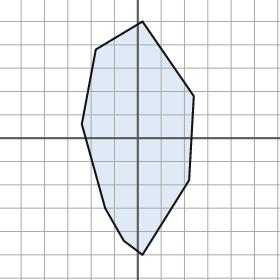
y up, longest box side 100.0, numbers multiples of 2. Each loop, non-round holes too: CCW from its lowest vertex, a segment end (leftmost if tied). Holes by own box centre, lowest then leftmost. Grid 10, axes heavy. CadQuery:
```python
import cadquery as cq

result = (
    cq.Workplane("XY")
    .moveTo(2.0, -50.0)
    .lineTo(22.0, -18.0)
    .lineTo(24.0, 18.0)
    .lineTo(2.0, 50.0)
    .lineTo(-18.0, 38.0)
    .lineTo(-24.0, 6.0)
    .lineTo(-14.0, -30.0)
    .lineTo(-6.0, -44.0)
    .close()
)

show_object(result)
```